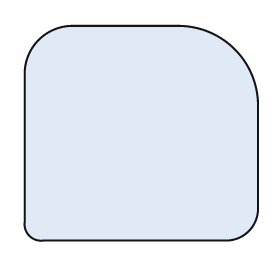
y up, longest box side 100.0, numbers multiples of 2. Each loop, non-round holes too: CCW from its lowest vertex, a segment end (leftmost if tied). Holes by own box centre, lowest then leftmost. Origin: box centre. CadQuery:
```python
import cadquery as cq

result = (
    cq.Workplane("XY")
    .moveTo(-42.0, -46.0)
    .lineTo(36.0, -46.0)
    .threePointArc((46.0, -42.0), (50.0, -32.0))
    .lineTo(50.0, 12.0)
    .threePointArc((40.0, 36.0), (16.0, 46.0))
    .lineTo(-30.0, 46.0)
    .threePointArc((-44.0, 40.0), (-50.0, 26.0))
    .lineTo(-50.0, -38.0)
    .threePointArc((-48.0, -44.0), (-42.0, -46.0))
    .close()
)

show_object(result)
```